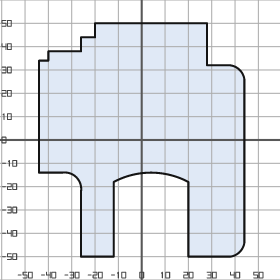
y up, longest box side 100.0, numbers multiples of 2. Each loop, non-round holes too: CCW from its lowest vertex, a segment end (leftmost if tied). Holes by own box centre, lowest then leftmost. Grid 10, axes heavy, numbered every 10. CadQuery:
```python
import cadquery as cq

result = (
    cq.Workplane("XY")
    .moveTo(-26.0, -50.0)
    .lineTo(-12.0, -50.0)
    .lineTo(-12.0, -18.0)
    .threePointArc((4.0, -14.0), (20.0, -18.0))
    .lineTo(20.0, -50.0)
    .lineTo(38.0, -50.0)
    .threePointArc((42.0, -48.0), (44.0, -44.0))
    .lineTo(44.0, 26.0)
    .threePointArc((42.0, 30.0), (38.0, 32.0))
    .lineTo(28.0, 32.0)
    .lineTo(28.0, 50.0)
    .lineTo(-20.0, 50.0)
    .lineTo(-20.0, 44.0)
    .lineTo(-26.0, 44.0)
    .lineTo(-26.0, 38.0)
    .lineTo(-40.0, 38.0)
    .lineTo(-40.0, 34.0)
    .lineTo(-44.0, 34.0)
    .lineTo(-44.0, -14.0)
    .lineTo(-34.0, -14.0)
    .threePointArc((-28.0, -16.0), (-26.0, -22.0))
    .close()
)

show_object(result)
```